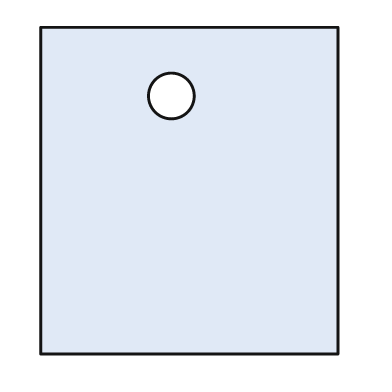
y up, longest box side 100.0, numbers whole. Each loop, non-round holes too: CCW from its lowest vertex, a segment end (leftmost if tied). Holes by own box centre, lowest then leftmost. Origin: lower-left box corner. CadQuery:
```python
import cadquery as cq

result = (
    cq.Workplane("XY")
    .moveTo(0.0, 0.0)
    .lineTo(91.0, 0.0)
    .lineTo(91.0, 100.0)
    .lineTo(0.0, 100.0)
    .close()
    .moveTo(40.0, 79.0)
    .circle(7.0)
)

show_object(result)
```